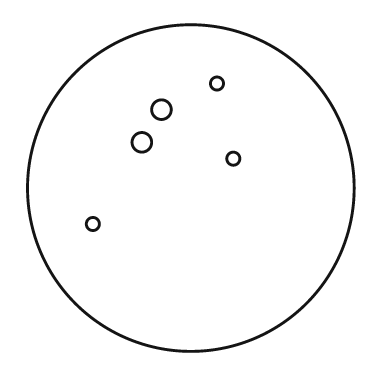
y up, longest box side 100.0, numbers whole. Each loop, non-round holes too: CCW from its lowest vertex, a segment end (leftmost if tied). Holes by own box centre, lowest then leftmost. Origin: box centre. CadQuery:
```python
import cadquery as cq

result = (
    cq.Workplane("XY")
    .moveTo(0.0, 0.0)
    .circle(50.0)
    .moveTo(-30.0, -11.0)
    .circle(2.0)
    .moveTo(13.0, 9.0)
    .circle(2.0)
    .moveTo(-15.0, 14.0)
    .circle(3.0)
    .moveTo(-9.0, 24.0)
    .circle(3.0)
    .moveTo(8.0, 32.0)
    .circle(2.0)
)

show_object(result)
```